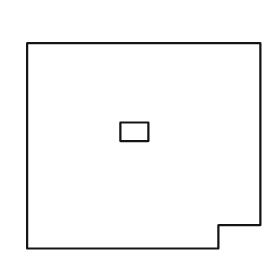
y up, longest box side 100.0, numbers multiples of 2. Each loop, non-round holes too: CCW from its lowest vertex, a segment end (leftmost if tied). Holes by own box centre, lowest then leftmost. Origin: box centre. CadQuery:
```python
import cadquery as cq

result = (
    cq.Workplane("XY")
    .moveTo(-50.0, -44.0)
    .lineTo(32.0, -44.0)
    .lineTo(32.0, -34.0)
    .lineTo(50.0, -34.0)
    .lineTo(50.0, 44.0)
    .lineTo(-50.0, 44.0)
    .close()
    .moveTo(-10.0, 2.0)
    .lineTo(2.0, 2.0)
    .lineTo(2.0, 10.0)
    .lineTo(-10.0, 10.0)
    .close()
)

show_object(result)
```